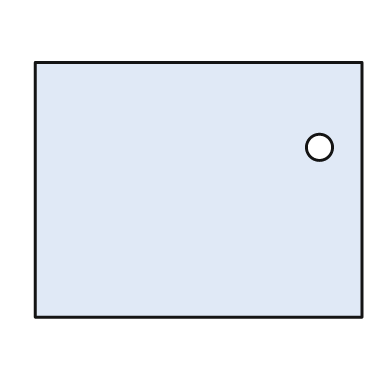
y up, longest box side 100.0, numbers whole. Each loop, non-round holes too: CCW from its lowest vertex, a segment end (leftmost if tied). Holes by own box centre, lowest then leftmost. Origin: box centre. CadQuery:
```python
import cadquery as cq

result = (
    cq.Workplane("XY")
    .moveTo(-50.0, -39.0)
    .lineTo(50.0, -39.0)
    .lineTo(50.0, 39.0)
    .lineTo(-50.0, 39.0)
    .close()
    .moveTo(37.0, 13.0)
    .circle(4.0)
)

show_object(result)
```